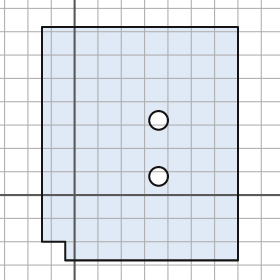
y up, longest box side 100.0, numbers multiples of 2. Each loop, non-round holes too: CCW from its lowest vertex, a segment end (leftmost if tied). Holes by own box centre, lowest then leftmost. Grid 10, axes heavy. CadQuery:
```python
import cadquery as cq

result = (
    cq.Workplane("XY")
    .moveTo(-4.0, -28.0)
    .lineTo(70.0, -28.0)
    .lineTo(70.0, 72.0)
    .lineTo(-14.0, 72.0)
    .lineTo(-14.0, -20.0)
    .lineTo(-4.0, -20.0)
    .close()
    .moveTo(36.0, 8.0)
    .circle(4.0)
    .moveTo(36.0, 32.0)
    .circle(4.0)
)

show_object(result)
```